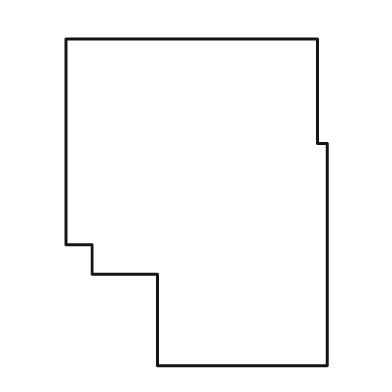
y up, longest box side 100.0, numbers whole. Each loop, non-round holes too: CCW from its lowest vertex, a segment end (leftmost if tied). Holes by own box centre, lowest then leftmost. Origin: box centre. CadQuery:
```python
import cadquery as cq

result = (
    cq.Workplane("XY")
    .moveTo(-12.0, -50.0)
    .lineTo(40.0, -50.0)
    .lineTo(40.0, 18.0)
    .lineTo(37.0, 18.0)
    .lineTo(37.0, 50.0)
    .lineTo(-40.0, 50.0)
    .lineTo(-40.0, -13.0)
    .lineTo(-32.0, -13.0)
    .lineTo(-32.0, -22.0)
    .lineTo(-12.0, -22.0)
    .close()
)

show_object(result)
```